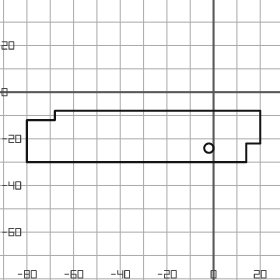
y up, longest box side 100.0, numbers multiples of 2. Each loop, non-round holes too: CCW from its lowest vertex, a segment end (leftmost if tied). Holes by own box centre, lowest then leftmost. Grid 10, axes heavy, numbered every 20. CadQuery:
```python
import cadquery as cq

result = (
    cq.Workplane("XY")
    .moveTo(-80.0, -30.0)
    .lineTo(14.0, -30.0)
    .lineTo(14.0, -22.0)
    .lineTo(20.0, -22.0)
    .lineTo(20.0, -8.0)
    .lineTo(-68.0, -8.0)
    .lineTo(-68.0, -12.0)
    .lineTo(-80.0, -12.0)
    .close()
    .moveTo(-2.0, -24.0)
    .circle(2.0)
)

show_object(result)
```